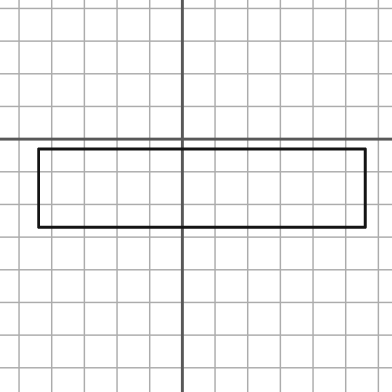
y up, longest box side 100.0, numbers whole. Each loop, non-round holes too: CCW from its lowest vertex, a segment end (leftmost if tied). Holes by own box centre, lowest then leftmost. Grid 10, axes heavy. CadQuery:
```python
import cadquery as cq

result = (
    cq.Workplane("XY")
    .moveTo(-44.0, -27.0)
    .lineTo(56.0, -27.0)
    .lineTo(56.0, -3.0)
    .lineTo(-44.0, -3.0)
    .close()
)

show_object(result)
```